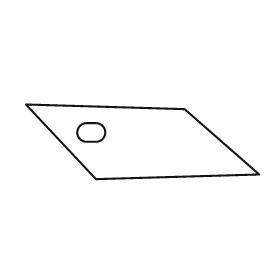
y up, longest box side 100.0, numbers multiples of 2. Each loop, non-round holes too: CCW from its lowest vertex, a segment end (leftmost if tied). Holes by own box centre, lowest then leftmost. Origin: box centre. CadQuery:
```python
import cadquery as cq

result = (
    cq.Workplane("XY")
    .moveTo(-20.0, -16.0)
    .lineTo(50.0, -14.0)
    .lineTo(18.0, 14.0)
    .lineTo(-50.0, 16.0)
    .close()
    .moveTo(-24.0, 0.0)
    .lineTo(-20.0, 0.0)
    .threePointArc((-16.0, 4.0), (-20.0, 8.0))
    .lineTo(-24.0, 8.0)
    .threePointArc((-28.0, 4.0), (-24.0, 0.0))
    .close()
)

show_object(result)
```